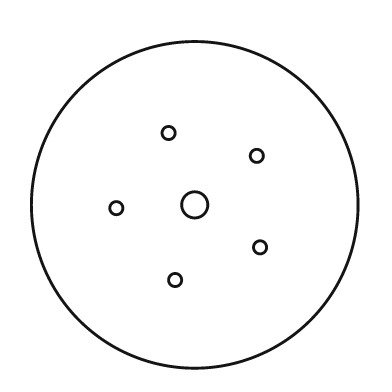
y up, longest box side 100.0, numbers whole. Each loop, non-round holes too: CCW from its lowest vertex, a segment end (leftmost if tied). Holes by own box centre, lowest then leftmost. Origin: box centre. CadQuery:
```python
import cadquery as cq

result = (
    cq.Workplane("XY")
    .moveTo(0.0, 0.0)
    .circle(50.0)
    .moveTo(-6.0, -23.0)
    .circle(2.0)
    .moveTo(20.0, -13.0)
    .circle(2.0)
    .moveTo(-24.0, -1.0)
    .circle(2.0)
    .moveTo(0.0, 0.0)
    .circle(4.0)
    .moveTo(19.0, 15.0)
    .circle(2.0)
    .moveTo(-8.0, 22.0)
    .circle(2.0)
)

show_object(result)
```